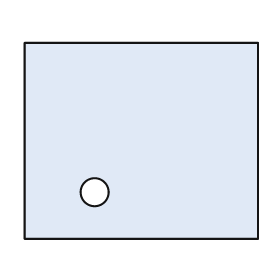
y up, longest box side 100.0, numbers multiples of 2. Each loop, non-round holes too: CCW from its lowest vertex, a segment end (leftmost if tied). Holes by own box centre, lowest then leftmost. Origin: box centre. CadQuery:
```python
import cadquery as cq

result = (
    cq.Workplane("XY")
    .moveTo(-50.0, -42.0)
    .lineTo(50.0, -42.0)
    .lineTo(50.0, 42.0)
    .lineTo(-50.0, 42.0)
    .close()
    .moveTo(-20.0, -22.0)
    .circle(6.0)
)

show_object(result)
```